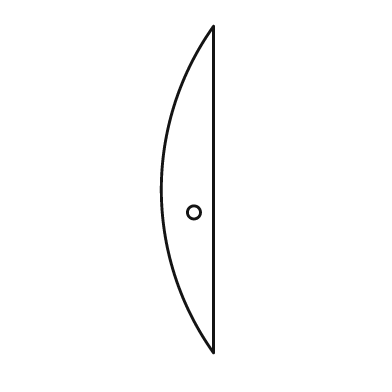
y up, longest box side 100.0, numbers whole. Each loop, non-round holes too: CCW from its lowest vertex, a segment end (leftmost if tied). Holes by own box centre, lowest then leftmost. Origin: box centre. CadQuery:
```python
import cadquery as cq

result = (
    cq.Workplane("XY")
    .moveTo(8.0, -50.0)
    .lineTo(8.0, 50.0)
    .threePointArc((-8.0, 0.0), (8.0, -50.0))
    .close()
    .moveTo(2.0, -7.0)
    .circle(2.0)
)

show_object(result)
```